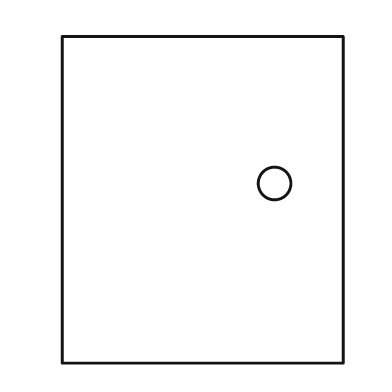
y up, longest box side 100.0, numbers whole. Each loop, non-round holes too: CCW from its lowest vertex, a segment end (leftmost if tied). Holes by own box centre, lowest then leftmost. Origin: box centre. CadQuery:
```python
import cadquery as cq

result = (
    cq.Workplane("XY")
    .moveTo(-43.0, -50.0)
    .lineTo(43.0, -50.0)
    .lineTo(43.0, 50.0)
    .lineTo(-43.0, 50.0)
    .close()
    .moveTo(22.0, 5.0)
    .circle(5.0)
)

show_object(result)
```